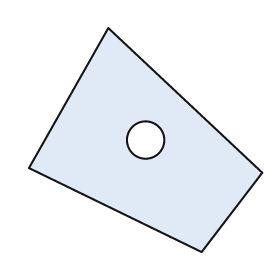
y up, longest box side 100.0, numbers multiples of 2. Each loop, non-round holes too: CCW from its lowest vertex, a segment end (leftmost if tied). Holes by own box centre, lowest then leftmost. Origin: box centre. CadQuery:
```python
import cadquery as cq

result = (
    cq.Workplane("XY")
    .moveTo(24.0, -48.0)
    .lineTo(50.0, -14.0)
    .lineTo(-16.0, 48.0)
    .lineTo(-50.0, -12.0)
    .close()
    .moveTo(0.0, 0.0)
    .circle(8.0)
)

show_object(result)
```